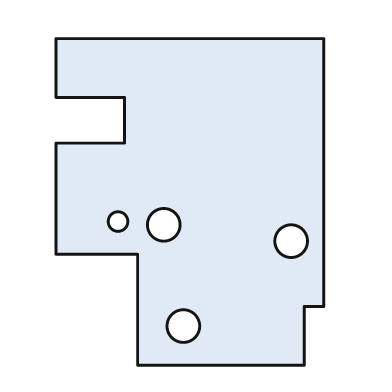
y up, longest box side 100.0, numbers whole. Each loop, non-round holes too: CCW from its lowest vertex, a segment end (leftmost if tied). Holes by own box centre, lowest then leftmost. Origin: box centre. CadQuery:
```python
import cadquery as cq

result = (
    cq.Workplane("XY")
    .moveTo(-16.0, -50.0)
    .lineTo(35.0, -50.0)
    .lineTo(35.0, -32.0)
    .lineTo(41.0, -32.0)
    .lineTo(41.0, 50.0)
    .lineTo(-41.0, 50.0)
    .lineTo(-41.0, 32.0)
    .lineTo(-20.0, 32.0)
    .lineTo(-20.0, 18.0)
    .lineTo(-41.0, 18.0)
    .lineTo(-41.0, -16.0)
    .lineTo(-16.0, -16.0)
    .close()
    .moveTo(-2.0, -38.0)
    .circle(5.0)
    .moveTo(31.0, -12.0)
    .circle(5.0)
    .moveTo(-8.0, -7.0)
    .circle(5.0)
    .moveTo(-22.0, -6.0)
    .circle(3.0)
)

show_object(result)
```